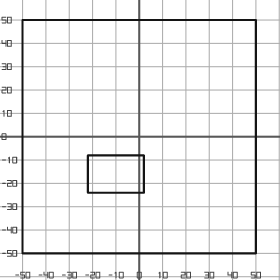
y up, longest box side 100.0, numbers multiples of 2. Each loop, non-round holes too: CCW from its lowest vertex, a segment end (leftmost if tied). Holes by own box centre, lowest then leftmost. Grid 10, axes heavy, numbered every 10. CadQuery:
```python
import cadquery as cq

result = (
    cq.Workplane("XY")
    .moveTo(-50.0, -50.0)
    .lineTo(50.0, -50.0)
    .lineTo(50.0, 50.0)
    .lineTo(-50.0, 50.0)
    .close()
    .moveTo(-22.0, -24.0)
    .lineTo(2.0, -24.0)
    .lineTo(2.0, -8.0)
    .lineTo(-22.0, -8.0)
    .close()
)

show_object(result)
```